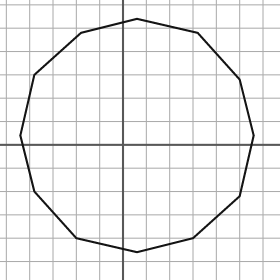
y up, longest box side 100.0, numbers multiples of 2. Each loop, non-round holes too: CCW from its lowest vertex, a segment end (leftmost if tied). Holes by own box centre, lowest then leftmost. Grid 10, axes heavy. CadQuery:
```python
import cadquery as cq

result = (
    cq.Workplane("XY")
    .moveTo(6.0, -46.0)
    .lineTo(30.0, -40.0)
    .lineTo(50.0, -22.0)
    .lineTo(56.0, 4.0)
    .lineTo(50.0, 28.0)
    .lineTo(32.0, 48.0)
    .lineTo(6.0, 54.0)
    .lineTo(-18.0, 48.0)
    .lineTo(-38.0, 30.0)
    .lineTo(-44.0, 4.0)
    .lineTo(-38.0, -20.0)
    .lineTo(-20.0, -40.0)
    .close()
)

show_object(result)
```